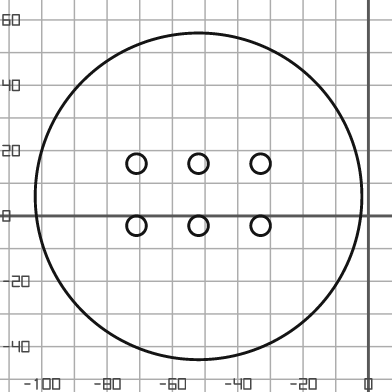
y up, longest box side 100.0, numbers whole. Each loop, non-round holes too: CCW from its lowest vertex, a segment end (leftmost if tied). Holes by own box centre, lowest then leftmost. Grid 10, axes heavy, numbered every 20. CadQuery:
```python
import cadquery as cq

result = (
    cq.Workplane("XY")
    .moveTo(-52.0, 6.0)
    .circle(50.0)
    .moveTo(-71.0, -3.0)
    .circle(3.0)
    .moveTo(-52.0, -3.0)
    .circle(3.0)
    .moveTo(-33.0, -3.0)
    .circle(3.0)
    .moveTo(-71.0, 16.0)
    .circle(3.0)
    .moveTo(-52.0, 16.0)
    .circle(3.0)
    .moveTo(-33.0, 16.0)
    .circle(3.0)
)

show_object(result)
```